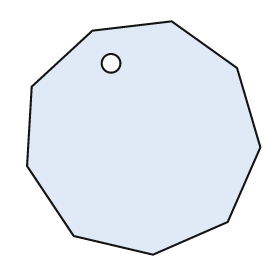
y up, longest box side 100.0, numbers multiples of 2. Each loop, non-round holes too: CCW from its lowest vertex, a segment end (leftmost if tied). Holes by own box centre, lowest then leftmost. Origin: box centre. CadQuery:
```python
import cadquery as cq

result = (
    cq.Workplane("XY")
    .moveTo(4.0, -50.0)
    .lineTo(36.0, -36.0)
    .lineTo(50.0, -4.0)
    .lineTo(40.0, 30.0)
    .lineTo(12.0, 50.0)
    .lineTo(-22.0, 46.0)
    .lineTo(-48.0, 22.0)
    .lineTo(-50.0, -12.0)
    .lineTo(-30.0, -42.0)
    .close()
    .moveTo(-14.0, 32.0)
    .circle(4.0)
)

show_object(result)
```